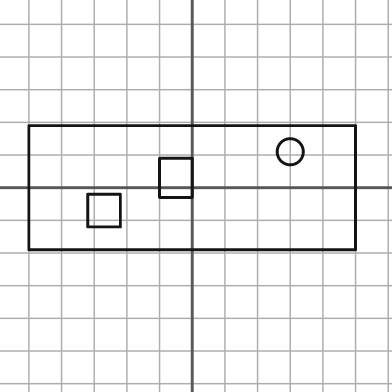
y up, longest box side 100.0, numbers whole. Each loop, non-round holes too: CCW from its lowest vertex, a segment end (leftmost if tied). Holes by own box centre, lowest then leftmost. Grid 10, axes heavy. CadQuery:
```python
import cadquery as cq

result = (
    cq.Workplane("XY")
    .moveTo(-50.0, -19.0)
    .lineTo(50.0, -19.0)
    .lineTo(50.0, 19.0)
    .lineTo(-50.0, 19.0)
    .close()
    .moveTo(-32.0, -12.0)
    .lineTo(-22.0, -12.0)
    .lineTo(-22.0, -2.0)
    .lineTo(-32.0, -2.0)
    .close()
    .moveTo(-10.0, -3.0)
    .lineTo(0.0, -3.0)
    .lineTo(0.0, 9.0)
    .lineTo(-10.0, 9.0)
    .close()
    .moveTo(30.0, 11.0)
    .circle(4.0)
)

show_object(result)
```